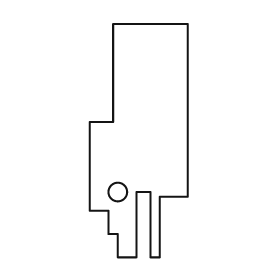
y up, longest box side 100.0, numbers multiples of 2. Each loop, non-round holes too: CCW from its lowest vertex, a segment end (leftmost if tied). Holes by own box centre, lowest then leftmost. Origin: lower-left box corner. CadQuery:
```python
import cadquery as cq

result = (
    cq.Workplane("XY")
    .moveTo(12.0, 0.0)
    .lineTo(20.0, 0.0)
    .lineTo(20.0, 28.0)
    .lineTo(26.0, 28.0)
    .lineTo(26.0, 0.0)
    .lineTo(30.0, 0.0)
    .lineTo(30.0, 26.0)
    .lineTo(42.0, 26.0)
    .lineTo(42.0, 100.0)
    .lineTo(10.0, 100.0)
    .lineTo(10.0, 58.0)
    .lineTo(0.0, 58.0)
    .lineTo(0.0, 20.0)
    .lineTo(8.0, 20.0)
    .lineTo(8.0, 10.0)
    .lineTo(12.0, 10.0)
    .close()
    .moveTo(12.0, 28.0)
    .circle(4.0)
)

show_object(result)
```